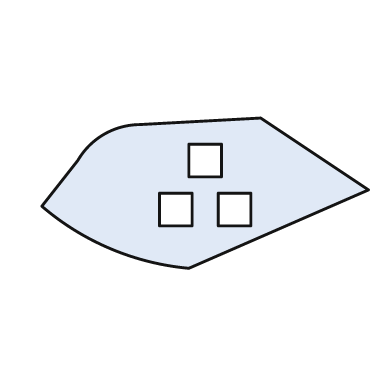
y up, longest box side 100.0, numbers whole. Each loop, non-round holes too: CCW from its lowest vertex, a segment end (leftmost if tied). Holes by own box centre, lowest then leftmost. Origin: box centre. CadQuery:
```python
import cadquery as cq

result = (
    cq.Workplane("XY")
    .moveTo(-5.0, -23.0)
    .lineTo(50.0, 1.0)
    .lineTo(17.0, 23.0)
    .lineTo(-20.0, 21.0)
    .threePointArc((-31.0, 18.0), (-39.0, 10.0))
    .lineTo(-50.0, -4.0)
    .threePointArc((-29.0, -17.0), (-5.0, -23.0))
    .close()
    .moveTo(-14.0, -10.0)
    .lineTo(-4.0, -10.0)
    .lineTo(-4.0, 0.0)
    .lineTo(-14.0, 0.0)
    .close()
    .moveTo(4.0, -10.0)
    .lineTo(14.0, -10.0)
    .lineTo(14.0, 0.0)
    .lineTo(4.0, 0.0)
    .close()
    .moveTo(-5.0, 5.0)
    .lineTo(5.0, 5.0)
    .lineTo(5.0, 15.0)
    .lineTo(-5.0, 15.0)
    .close()
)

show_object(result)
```